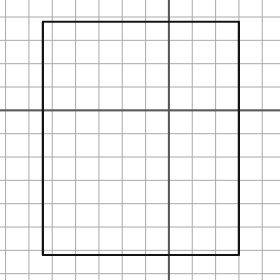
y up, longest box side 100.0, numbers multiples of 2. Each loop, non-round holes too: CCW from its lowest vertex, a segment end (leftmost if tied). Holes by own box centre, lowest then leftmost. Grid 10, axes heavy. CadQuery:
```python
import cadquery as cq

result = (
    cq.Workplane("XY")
    .moveTo(-54.0, -62.0)
    .lineTo(30.0, -62.0)
    .lineTo(30.0, 38.0)
    .lineTo(-54.0, 38.0)
    .close()
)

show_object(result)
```